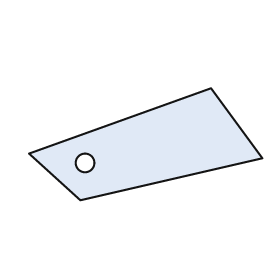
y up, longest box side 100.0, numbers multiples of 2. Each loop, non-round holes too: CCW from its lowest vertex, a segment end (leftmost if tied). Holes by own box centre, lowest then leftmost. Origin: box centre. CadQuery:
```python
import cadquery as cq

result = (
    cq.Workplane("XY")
    .moveTo(-28.0, -24.0)
    .lineTo(50.0, -6.0)
    .lineTo(28.0, 24.0)
    .lineTo(-50.0, -4.0)
    .close()
    .moveTo(-26.0, -8.0)
    .circle(4.0)
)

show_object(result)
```